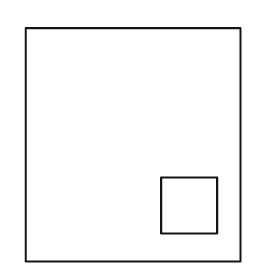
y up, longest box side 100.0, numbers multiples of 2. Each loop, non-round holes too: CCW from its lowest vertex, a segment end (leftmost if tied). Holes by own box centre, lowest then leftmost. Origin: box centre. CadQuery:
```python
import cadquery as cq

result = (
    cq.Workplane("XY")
    .moveTo(-46.0, -50.0)
    .lineTo(46.0, -50.0)
    .lineTo(46.0, 50.0)
    .lineTo(-46.0, 50.0)
    .close()
    .moveTo(12.0, -38.0)
    .lineTo(36.0, -38.0)
    .lineTo(36.0, -14.0)
    .lineTo(12.0, -14.0)
    .close()
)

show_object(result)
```